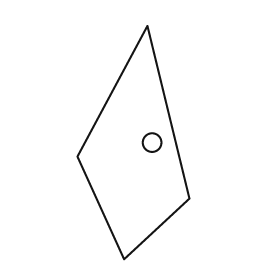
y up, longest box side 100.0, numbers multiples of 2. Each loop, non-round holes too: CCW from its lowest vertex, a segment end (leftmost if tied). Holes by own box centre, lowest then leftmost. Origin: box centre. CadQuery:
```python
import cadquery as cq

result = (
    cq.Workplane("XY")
    .moveTo(-4.0, -50.0)
    .lineTo(24.0, -24.0)
    .lineTo(6.0, 50.0)
    .lineTo(-24.0, -6.0)
    .close()
    .moveTo(8.0, 0.0)
    .circle(4.0)
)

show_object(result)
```